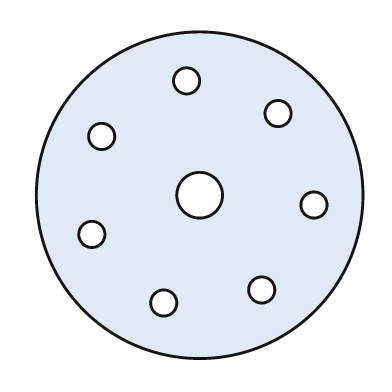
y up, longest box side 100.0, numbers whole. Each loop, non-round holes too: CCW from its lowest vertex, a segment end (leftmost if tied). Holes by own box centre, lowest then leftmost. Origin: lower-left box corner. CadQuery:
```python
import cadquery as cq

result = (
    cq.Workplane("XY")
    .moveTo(50.0, 50.0)
    .circle(50.0)
    .moveTo(39.0, 17.0)
    .circle(4.0)
    .moveTo(69.0, 21.0)
    .circle(4.0)
    .moveTo(17.0, 38.0)
    .circle(4.0)
    .moveTo(85.0, 47.0)
    .circle(4.0)
    .moveTo(50.0, 50.0)
    .circle(7.0)
    .moveTo(20.0, 68.0)
    .circle(4.0)
    .moveTo(74.0, 75.0)
    .circle(4.0)
    .moveTo(46.0, 85.0)
    .circle(4.0)
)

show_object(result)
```